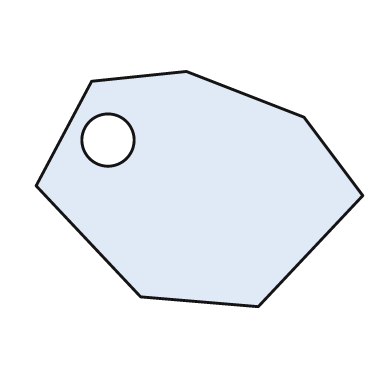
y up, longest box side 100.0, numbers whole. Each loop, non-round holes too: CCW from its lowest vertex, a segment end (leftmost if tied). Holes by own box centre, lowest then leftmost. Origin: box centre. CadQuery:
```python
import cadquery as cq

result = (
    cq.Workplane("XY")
    .moveTo(18.0, -36.0)
    .lineTo(50.0, -2.0)
    .lineTo(32.0, 22.0)
    .lineTo(-4.0, 36.0)
    .lineTo(-33.0, 33.0)
    .lineTo(-50.0, 1.0)
    .lineTo(-18.0, -33.0)
    .close()
    .moveTo(-28.0, 15.0)
    .circle(8.0)
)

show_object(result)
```